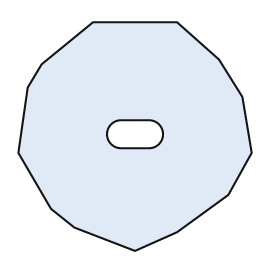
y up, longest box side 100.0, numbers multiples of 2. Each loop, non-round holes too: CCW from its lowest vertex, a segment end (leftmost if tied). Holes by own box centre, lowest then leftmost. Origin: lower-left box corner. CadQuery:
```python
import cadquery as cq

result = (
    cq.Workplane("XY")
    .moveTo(50.0, 0.0)
    .lineTo(68.0, 8.0)
    .lineTo(90.0, 24.0)
    .lineTo(100.0, 42.0)
    .lineTo(96.0, 66.0)
    .lineTo(86.0, 82.0)
    .lineTo(68.0, 98.0)
    .lineTo(32.0, 98.0)
    .lineTo(10.0, 80.0)
    .lineTo(4.0, 70.0)
    .lineTo(0.0, 42.0)
    .lineTo(14.0, 18.0)
    .lineTo(24.0, 10.0)
    .close()
    .moveTo(44.0, 44.0)
    .lineTo(56.0, 44.0)
    .threePointArc((62.0, 50.0), (56.0, 56.0))
    .lineTo(44.0, 56.0)
    .threePointArc((38.0, 50.0), (44.0, 44.0))
    .close()
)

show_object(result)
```